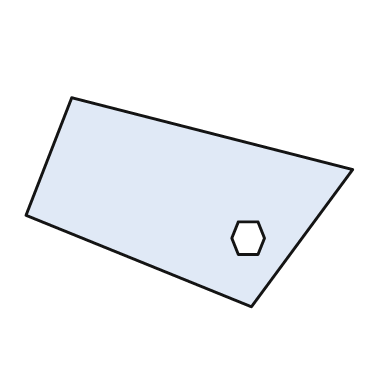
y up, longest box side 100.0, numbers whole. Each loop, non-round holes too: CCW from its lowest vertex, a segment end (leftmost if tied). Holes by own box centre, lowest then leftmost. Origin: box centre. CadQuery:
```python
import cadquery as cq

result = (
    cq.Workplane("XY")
    .moveTo(19.0, -32.0)
    .lineTo(50.0, 10.0)
    .lineTo(-36.0, 32.0)
    .lineTo(-50.0, -4.0)
    .close()
    .moveTo(15.0, -16.0)
    .lineTo(21.0, -16.0)
    .lineTo(23.0, -11.0)
    .lineTo(21.0, -6.0)
    .lineTo(15.0, -6.0)
    .lineTo(13.0, -11.0)
    .close()
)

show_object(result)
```